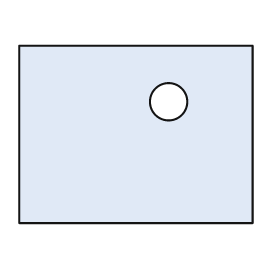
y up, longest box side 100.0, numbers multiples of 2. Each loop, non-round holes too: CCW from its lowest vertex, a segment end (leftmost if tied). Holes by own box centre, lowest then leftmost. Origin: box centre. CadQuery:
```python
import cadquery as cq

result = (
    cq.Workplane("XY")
    .moveTo(-50.0, -38.0)
    .lineTo(50.0, -38.0)
    .lineTo(50.0, 38.0)
    .lineTo(-50.0, 38.0)
    .close()
    .moveTo(14.0, 14.0)
    .circle(8.0)
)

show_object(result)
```